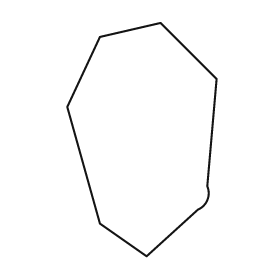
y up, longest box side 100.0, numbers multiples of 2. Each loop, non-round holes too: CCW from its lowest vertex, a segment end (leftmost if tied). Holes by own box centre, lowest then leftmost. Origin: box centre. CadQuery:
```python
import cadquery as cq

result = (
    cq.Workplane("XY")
    .moveTo(2.0, -50.0)
    .lineTo(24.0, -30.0)
    .threePointArc((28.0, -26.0), (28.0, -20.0))
    .lineTo(32.0, 26.0)
    .lineTo(8.0, 50.0)
    .lineTo(-18.0, 44.0)
    .lineTo(-32.0, 14.0)
    .lineTo(-18.0, -36.0)
    .close()
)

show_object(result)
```